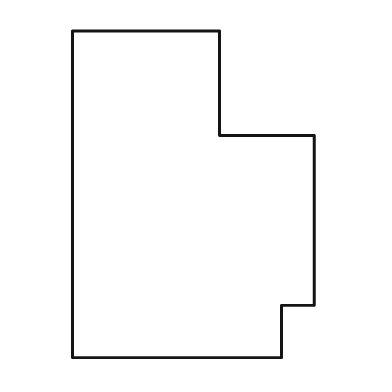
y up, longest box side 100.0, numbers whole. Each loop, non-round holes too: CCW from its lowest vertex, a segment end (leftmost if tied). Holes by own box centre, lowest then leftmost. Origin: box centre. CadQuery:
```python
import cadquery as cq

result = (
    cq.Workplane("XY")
    .moveTo(-37.0, -50.0)
    .lineTo(27.0, -50.0)
    .lineTo(27.0, -34.0)
    .lineTo(37.0, -34.0)
    .lineTo(37.0, 18.0)
    .lineTo(8.0, 18.0)
    .lineTo(8.0, 50.0)
    .lineTo(-37.0, 50.0)
    .close()
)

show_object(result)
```